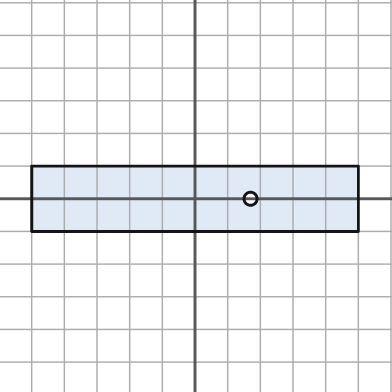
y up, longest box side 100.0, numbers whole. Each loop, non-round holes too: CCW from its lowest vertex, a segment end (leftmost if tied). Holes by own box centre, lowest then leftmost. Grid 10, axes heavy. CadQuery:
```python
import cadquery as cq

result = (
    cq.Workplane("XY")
    .moveTo(-50.0, -10.0)
    .lineTo(50.0, -10.0)
    .lineTo(50.0, 10.0)
    .lineTo(-50.0, 10.0)
    .close()
    .moveTo(17.0, 0.0)
    .circle(2.0)
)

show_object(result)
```